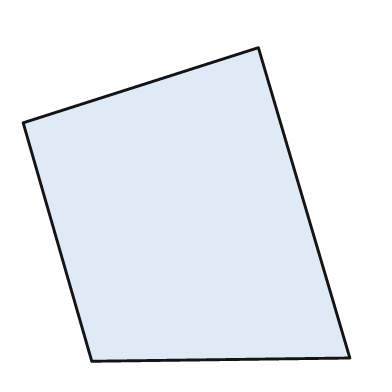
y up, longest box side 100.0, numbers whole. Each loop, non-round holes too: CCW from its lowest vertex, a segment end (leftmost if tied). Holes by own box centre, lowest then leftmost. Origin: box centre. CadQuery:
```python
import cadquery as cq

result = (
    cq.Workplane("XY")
    .moveTo(-29.0, -48.0)
    .lineTo(50.0, -47.0)
    .lineTo(22.0, 48.0)
    .lineTo(-50.0, 25.0)
    .close()
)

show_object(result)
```